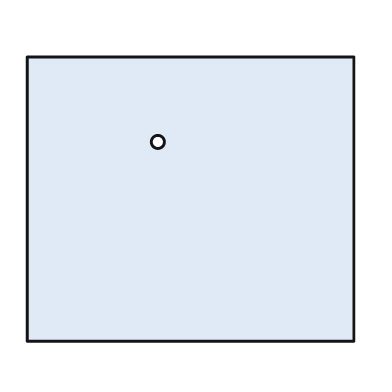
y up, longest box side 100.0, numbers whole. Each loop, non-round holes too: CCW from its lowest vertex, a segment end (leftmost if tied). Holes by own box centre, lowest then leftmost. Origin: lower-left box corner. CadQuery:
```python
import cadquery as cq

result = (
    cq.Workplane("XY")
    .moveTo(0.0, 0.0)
    .lineTo(100.0, 0.0)
    .lineTo(100.0, 87.0)
    .lineTo(0.0, 87.0)
    .close()
    .moveTo(40.0, 61.0)
    .circle(2.0)
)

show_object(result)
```